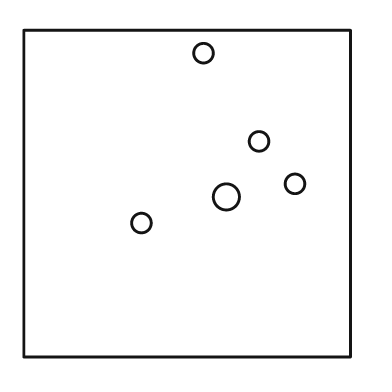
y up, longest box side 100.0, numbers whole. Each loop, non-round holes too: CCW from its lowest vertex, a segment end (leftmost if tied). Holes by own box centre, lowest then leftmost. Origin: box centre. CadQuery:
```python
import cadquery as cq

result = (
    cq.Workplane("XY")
    .moveTo(-50.0, -50.0)
    .lineTo(50.0, -50.0)
    .lineTo(50.0, 50.0)
    .lineTo(-50.0, 50.0)
    .close()
    .moveTo(-14.0, -9.0)
    .circle(3.0)
    .moveTo(12.0, -1.0)
    .circle(4.0)
    .moveTo(33.0, 3.0)
    .circle(3.0)
    .moveTo(22.0, 16.0)
    .circle(3.0)
    .moveTo(5.0, 43.0)
    .circle(3.0)
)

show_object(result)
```